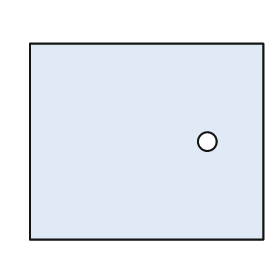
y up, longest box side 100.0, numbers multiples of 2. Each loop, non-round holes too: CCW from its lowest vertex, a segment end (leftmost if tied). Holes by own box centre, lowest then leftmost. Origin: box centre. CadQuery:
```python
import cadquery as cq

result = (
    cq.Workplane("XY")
    .moveTo(-50.0, -42.0)
    .lineTo(50.0, -42.0)
    .lineTo(50.0, 42.0)
    .lineTo(-50.0, 42.0)
    .close()
    .moveTo(26.0, 0.0)
    .circle(4.0)
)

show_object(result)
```